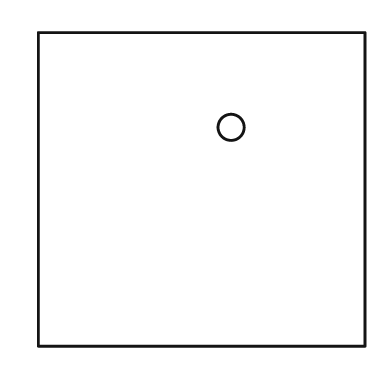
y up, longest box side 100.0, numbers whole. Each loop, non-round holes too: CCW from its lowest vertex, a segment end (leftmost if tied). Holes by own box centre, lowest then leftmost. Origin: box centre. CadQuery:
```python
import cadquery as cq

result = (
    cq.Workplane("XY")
    .moveTo(-50.0, -48.0)
    .lineTo(50.0, -48.0)
    .lineTo(50.0, 48.0)
    .lineTo(-50.0, 48.0)
    .close()
    .moveTo(9.0, 19.0)
    .circle(4.0)
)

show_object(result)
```